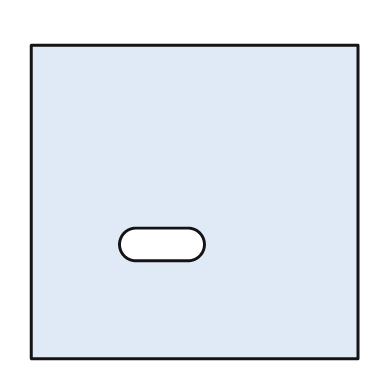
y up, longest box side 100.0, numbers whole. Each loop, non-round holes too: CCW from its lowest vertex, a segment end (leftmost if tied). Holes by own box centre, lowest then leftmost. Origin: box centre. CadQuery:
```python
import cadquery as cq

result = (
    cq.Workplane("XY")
    .moveTo(-50.0, -48.0)
    .lineTo(50.0, -48.0)
    .lineTo(50.0, 48.0)
    .lineTo(-50.0, 48.0)
    .close()
    .moveTo(-18.0, -18.0)
    .lineTo(-2.0, -18.0)
    .threePointArc((3.0, -13.0), (-2.0, -8.0))
    .lineTo(-18.0, -8.0)
    .threePointArc((-23.0, -13.0), (-18.0, -18.0))
    .close()
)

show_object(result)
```